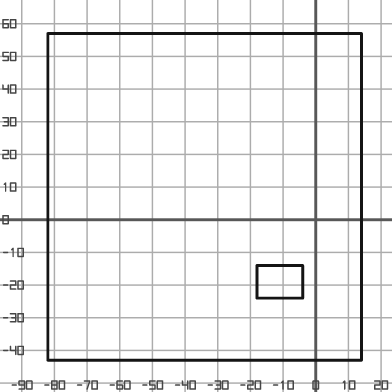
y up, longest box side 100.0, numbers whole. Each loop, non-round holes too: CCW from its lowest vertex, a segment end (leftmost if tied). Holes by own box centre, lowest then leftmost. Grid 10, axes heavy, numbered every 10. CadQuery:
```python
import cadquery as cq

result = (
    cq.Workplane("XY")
    .moveTo(-82.0, -43.0)
    .lineTo(14.0, -43.0)
    .lineTo(14.0, 57.0)
    .lineTo(-82.0, 57.0)
    .close()
    .moveTo(-18.0, -24.0)
    .lineTo(-4.0, -24.0)
    .lineTo(-4.0, -14.0)
    .lineTo(-18.0, -14.0)
    .close()
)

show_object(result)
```